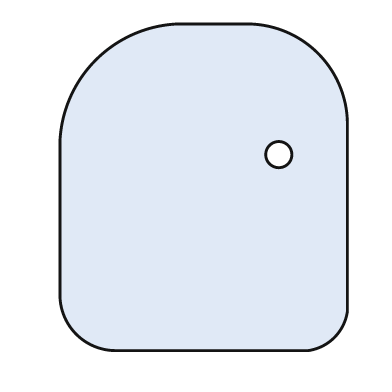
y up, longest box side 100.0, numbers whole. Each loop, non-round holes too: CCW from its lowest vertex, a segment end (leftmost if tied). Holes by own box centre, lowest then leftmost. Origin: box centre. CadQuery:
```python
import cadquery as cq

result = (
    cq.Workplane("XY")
    .moveTo(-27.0, -50.0)
    .lineTo(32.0, -50.0)
    .threePointArc((40.0, -46.0), (44.0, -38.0))
    .lineTo(44.0, 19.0)
    .threePointArc((35.0, 41.0), (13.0, 50.0))
    .lineTo(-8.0, 50.0)
    .threePointArc((-33.0, 39.0), (-44.0, 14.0))
    .lineTo(-44.0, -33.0)
    .threePointArc((-39.0, -45.0), (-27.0, -50.0))
    .close()
    .moveTo(23.0, 10.0)
    .circle(4.0)
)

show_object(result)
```